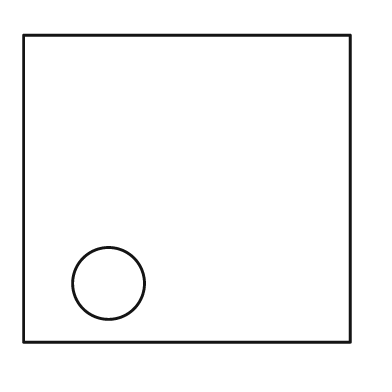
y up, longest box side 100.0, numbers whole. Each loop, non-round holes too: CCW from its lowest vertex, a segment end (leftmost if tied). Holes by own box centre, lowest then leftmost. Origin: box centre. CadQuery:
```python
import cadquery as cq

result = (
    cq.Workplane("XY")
    .moveTo(-50.0, -47.0)
    .lineTo(50.0, -47.0)
    .lineTo(50.0, 47.0)
    .lineTo(-50.0, 47.0)
    .close()
    .moveTo(-24.0, -29.0)
    .circle(11.0)
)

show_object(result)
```